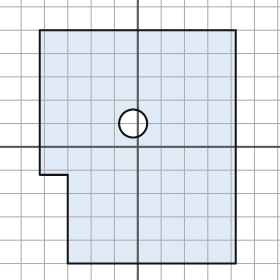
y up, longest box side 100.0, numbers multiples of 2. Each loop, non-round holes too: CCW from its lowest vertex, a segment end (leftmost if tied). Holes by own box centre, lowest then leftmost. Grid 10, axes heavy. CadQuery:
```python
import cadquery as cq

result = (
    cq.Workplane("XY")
    .moveTo(-30.0, -50.0)
    .lineTo(42.0, -50.0)
    .lineTo(42.0, 50.0)
    .lineTo(-42.0, 50.0)
    .lineTo(-42.0, -12.0)
    .lineTo(-30.0, -12.0)
    .close()
    .moveTo(-2.0, 10.0)
    .circle(6.0)
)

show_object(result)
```